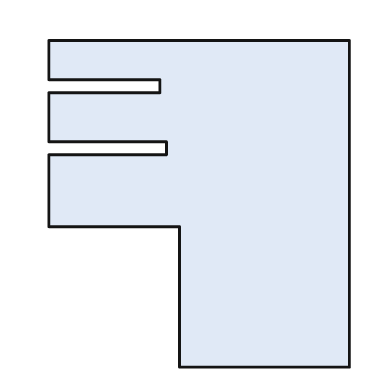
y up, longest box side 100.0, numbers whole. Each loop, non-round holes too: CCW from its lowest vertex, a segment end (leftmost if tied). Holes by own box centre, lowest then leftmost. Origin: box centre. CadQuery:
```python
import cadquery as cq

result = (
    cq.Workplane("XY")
    .moveTo(-6.0, -50.0)
    .lineTo(46.0, -50.0)
    .lineTo(46.0, 50.0)
    .lineTo(-46.0, 50.0)
    .lineTo(-46.0, 38.0)
    .lineTo(-12.0, 38.0)
    .lineTo(-12.0, 34.0)
    .lineTo(-46.0, 34.0)
    .lineTo(-46.0, 19.0)
    .lineTo(-10.0, 19.0)
    .lineTo(-10.0, 15.0)
    .lineTo(-46.0, 15.0)
    .lineTo(-46.0, -7.0)
    .lineTo(-6.0, -7.0)
    .close()
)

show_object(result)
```